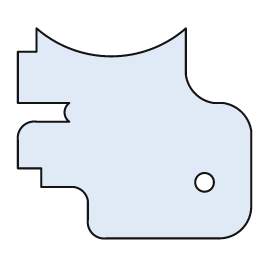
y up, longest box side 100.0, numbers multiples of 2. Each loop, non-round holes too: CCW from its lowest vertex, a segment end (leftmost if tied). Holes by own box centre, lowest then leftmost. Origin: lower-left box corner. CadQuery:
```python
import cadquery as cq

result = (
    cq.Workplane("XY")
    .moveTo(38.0, 0.0)
    .lineTo(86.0, 0.0)
    .threePointArc((96.0, 4.0), (100.0, 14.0))
    .lineTo(100.0, 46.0)
    .threePointArc((96.0, 54.0), (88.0, 58.0))
    .lineTo(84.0, 58.0)
    .threePointArc((76.0, 62.0), (72.0, 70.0))
    .lineTo(72.0, 90.0)
    .threePointArc((40.0, 78.0), (8.0, 90.0))
    .lineTo(8.0, 80.0)
    .lineTo(0.0, 80.0)
    .lineTo(0.0, 58.0)
    .lineTo(22.0, 58.0)
    .threePointArc((20.0, 54.0), (22.0, 50.0))
    .lineTo(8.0, 50.0)
    .threePointArc((2.0, 48.0), (0.0, 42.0))
    .lineTo(0.0, 30.0)
    .lineTo(10.0, 30.0)
    .lineTo(10.0, 22.0)
    .lineTo(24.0, 22.0)
    .threePointArc((28.0, 20.0), (30.0, 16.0))
    .lineTo(30.0, 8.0)
    .threePointArc((32.0, 2.0), (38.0, 0.0))
    .close()
    .moveTo(80.0, 24.0)
    .circle(4.0)
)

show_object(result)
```